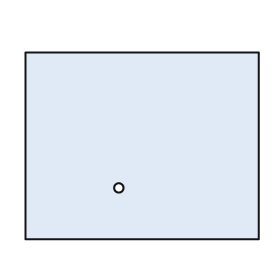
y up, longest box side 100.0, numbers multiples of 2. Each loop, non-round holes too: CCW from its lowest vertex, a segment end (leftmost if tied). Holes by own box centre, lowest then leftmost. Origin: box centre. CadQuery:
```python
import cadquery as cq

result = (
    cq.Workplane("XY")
    .moveTo(-50.0, -40.0)
    .lineTo(50.0, -40.0)
    .lineTo(50.0, 40.0)
    .lineTo(-50.0, 40.0)
    .close()
    .moveTo(-10.0, -18.0)
    .circle(2.0)
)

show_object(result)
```